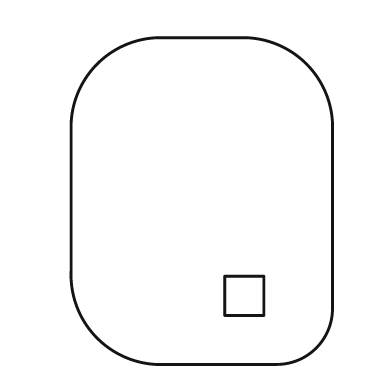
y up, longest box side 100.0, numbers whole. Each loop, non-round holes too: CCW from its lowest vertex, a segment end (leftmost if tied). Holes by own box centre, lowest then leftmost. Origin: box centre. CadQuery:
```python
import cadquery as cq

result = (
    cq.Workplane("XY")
    .moveTo(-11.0, -50.0)
    .lineTo(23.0, -50.0)
    .threePointArc((35.0, -45.0), (40.0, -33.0))
    .lineTo(40.0, 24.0)
    .threePointArc((32.0, 42.0), (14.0, 50.0))
    .lineTo(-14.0, 50.0)
    .threePointArc((-32.0, 42.0), (-40.0, 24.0))
    .lineTo(-40.0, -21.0)
    .threePointArc((-32.0, -42.0), (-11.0, -50.0))
    .close()
    .moveTo(7.0, -35.0)
    .lineTo(19.0, -35.0)
    .lineTo(19.0, -23.0)
    .lineTo(7.0, -23.0)
    .close()
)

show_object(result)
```